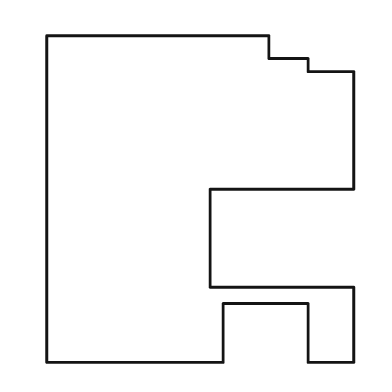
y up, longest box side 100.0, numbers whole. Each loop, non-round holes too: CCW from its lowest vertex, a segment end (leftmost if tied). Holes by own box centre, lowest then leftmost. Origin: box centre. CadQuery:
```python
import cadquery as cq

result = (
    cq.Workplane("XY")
    .moveTo(-47.0, -50.0)
    .lineTo(7.0, -50.0)
    .lineTo(7.0, -32.0)
    .lineTo(33.0, -32.0)
    .lineTo(33.0, -50.0)
    .lineTo(47.0, -50.0)
    .lineTo(47.0, -27.0)
    .lineTo(3.0, -27.0)
    .lineTo(3.0, 3.0)
    .lineTo(47.0, 3.0)
    .lineTo(47.0, 39.0)
    .lineTo(33.0, 39.0)
    .lineTo(33.0, 43.0)
    .lineTo(21.0, 43.0)
    .lineTo(21.0, 50.0)
    .lineTo(-47.0, 50.0)
    .close()
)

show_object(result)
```